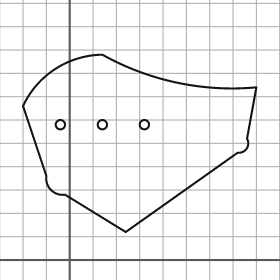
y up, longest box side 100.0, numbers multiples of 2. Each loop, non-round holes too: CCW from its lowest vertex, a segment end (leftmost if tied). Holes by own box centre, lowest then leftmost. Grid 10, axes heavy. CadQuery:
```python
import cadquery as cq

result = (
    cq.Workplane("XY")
    .moveTo(24.0, 12.0)
    .lineTo(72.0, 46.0)
    .threePointArc((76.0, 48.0), (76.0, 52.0))
    .lineTo(80.0, 74.0)
    .threePointArc((46.0, 76.0), (14.0, 88.0))
    .threePointArc((-6.0, 82.0), (-20.0, 66.0))
    .lineTo(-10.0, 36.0)
    .threePointArc((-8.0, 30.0), (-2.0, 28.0))
    .close()
    .moveTo(-4.0, 58.0)
    .circle(2.0)
    .moveTo(14.0, 58.0)
    .circle(2.0)
    .moveTo(32.0, 58.0)
    .circle(2.0)
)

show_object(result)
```